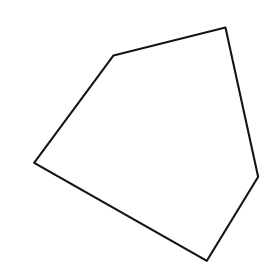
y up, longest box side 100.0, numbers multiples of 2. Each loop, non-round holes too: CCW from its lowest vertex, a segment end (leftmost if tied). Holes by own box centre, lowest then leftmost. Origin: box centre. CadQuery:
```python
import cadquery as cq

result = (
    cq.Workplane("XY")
    .moveTo(26.0, -50.0)
    .lineTo(48.0, -14.0)
    .lineTo(34.0, 50.0)
    .lineTo(-14.0, 38.0)
    .lineTo(-48.0, -8.0)
    .close()
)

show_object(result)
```